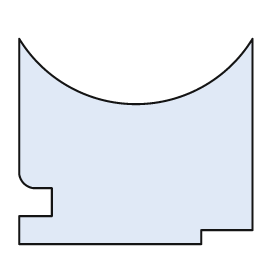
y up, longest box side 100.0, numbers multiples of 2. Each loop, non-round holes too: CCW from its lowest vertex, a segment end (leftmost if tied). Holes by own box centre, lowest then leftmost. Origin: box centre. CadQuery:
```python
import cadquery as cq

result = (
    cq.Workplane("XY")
    .moveTo(-50.0, -44.0)
    .lineTo(28.0, -44.0)
    .lineTo(28.0, -38.0)
    .lineTo(50.0, -38.0)
    .lineTo(50.0, 44.0)
    .threePointArc((0.0, 16.0), (-50.0, 44.0))
    .lineTo(-50.0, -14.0)
    .threePointArc((-48.0, -18.0), (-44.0, -20.0))
    .lineTo(-36.0, -20.0)
    .lineTo(-36.0, -32.0)
    .lineTo(-50.0, -32.0)
    .close()
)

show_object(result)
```